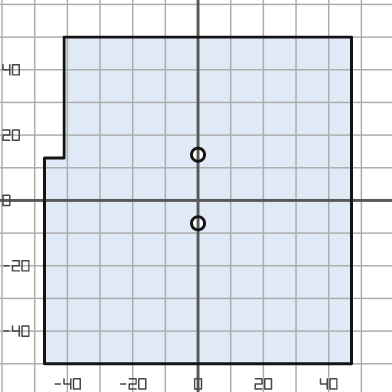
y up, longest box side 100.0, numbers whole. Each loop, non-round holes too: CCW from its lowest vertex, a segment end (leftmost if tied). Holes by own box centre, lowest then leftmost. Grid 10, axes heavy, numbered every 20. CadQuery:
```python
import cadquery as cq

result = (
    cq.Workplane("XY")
    .moveTo(-47.0, -50.0)
    .lineTo(47.0, -50.0)
    .lineTo(47.0, 50.0)
    .lineTo(-41.0, 50.0)
    .lineTo(-41.0, 13.0)
    .lineTo(-47.0, 13.0)
    .close()
    .moveTo(0.0, -7.0)
    .circle(2.0)
    .moveTo(0.0, 14.0)
    .circle(2.0)
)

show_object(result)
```